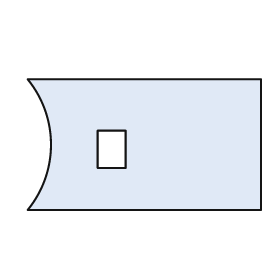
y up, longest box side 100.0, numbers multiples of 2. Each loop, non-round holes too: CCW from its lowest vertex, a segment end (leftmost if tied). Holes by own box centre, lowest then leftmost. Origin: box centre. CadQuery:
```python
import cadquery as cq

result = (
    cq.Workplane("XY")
    .moveTo(-50.0, -28.0)
    .lineTo(50.0, -28.0)
    .lineTo(50.0, 28.0)
    .lineTo(-50.0, 28.0)
    .threePointArc((-40.0, 0.0), (-50.0, -28.0))
    .close()
    .moveTo(-20.0, -10.0)
    .lineTo(-8.0, -10.0)
    .lineTo(-8.0, 6.0)
    .lineTo(-20.0, 6.0)
    .close()
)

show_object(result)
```